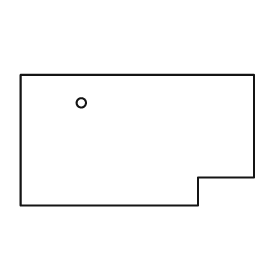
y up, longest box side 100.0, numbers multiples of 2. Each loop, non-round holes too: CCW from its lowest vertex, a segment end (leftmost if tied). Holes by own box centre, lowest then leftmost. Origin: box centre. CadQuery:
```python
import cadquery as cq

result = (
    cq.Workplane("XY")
    .moveTo(-50.0, -28.0)
    .lineTo(26.0, -28.0)
    .lineTo(26.0, -16.0)
    .lineTo(50.0, -16.0)
    .lineTo(50.0, 28.0)
    .lineTo(-50.0, 28.0)
    .close()
    .moveTo(-24.0, 16.0)
    .circle(2.0)
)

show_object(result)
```